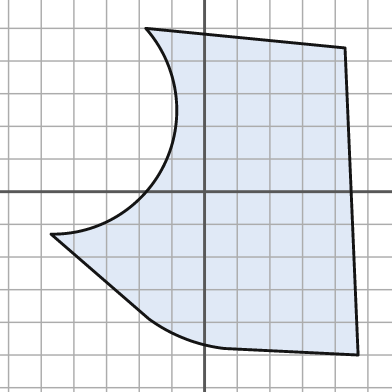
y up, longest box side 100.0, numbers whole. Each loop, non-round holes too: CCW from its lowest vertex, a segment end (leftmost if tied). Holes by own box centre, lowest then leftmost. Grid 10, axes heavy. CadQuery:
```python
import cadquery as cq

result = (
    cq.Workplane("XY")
    .moveTo(47.0, -50.0)
    .lineTo(43.0, 44.0)
    .lineTo(-18.0, 50.0)
    .threePointArc((-12.0, 9.0), (-47.0, -13.0))
    .lineTo(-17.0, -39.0)
    .threePointArc((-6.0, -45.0), (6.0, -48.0))
    .close()
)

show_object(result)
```